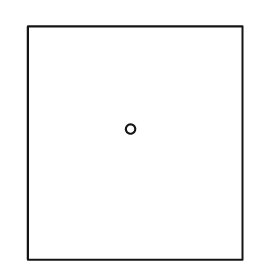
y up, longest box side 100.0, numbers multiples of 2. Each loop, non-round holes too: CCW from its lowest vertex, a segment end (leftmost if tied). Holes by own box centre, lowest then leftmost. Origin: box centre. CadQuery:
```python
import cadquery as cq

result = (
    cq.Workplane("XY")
    .moveTo(-46.0, -50.0)
    .lineTo(46.0, -50.0)
    .lineTo(46.0, 50.0)
    .lineTo(-46.0, 50.0)
    .close()
    .moveTo(-2.0, 6.0)
    .circle(2.0)
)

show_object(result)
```